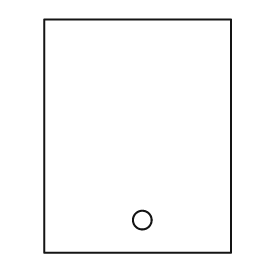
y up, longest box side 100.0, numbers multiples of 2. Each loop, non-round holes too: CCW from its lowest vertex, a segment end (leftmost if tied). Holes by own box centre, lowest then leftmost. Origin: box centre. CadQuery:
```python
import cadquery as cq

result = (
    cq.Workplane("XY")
    .moveTo(-40.0, -50.0)
    .lineTo(40.0, -50.0)
    .lineTo(40.0, 50.0)
    .lineTo(-40.0, 50.0)
    .close()
    .moveTo(2.0, -36.0)
    .circle(4.0)
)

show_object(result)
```